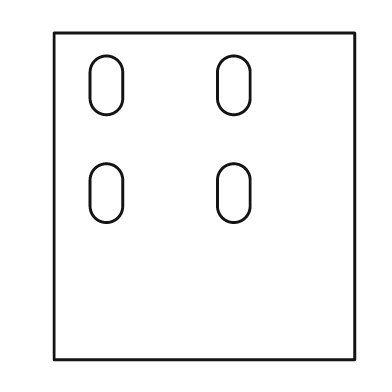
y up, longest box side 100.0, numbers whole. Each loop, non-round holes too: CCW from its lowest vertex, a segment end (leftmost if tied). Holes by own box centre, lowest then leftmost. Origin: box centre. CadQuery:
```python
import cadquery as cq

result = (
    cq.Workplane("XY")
    .moveTo(-46.0, -50.0)
    .lineTo(46.0, -50.0)
    .lineTo(46.0, 50.0)
    .lineTo(-46.0, 50.0)
    .close()
    .moveTo(-35.0, -3.0)
    .threePointArc((-30.0, -8.0), (-25.0, -3.0))
    .lineTo(-25.0, 5.0)
    .threePointArc((-30.0, 10.0), (-35.0, 5.0))
    .close()
    .moveTo(4.0, -3.0)
    .threePointArc((9.0, -8.0), (14.0, -3.0))
    .lineTo(14.0, 5.0)
    .threePointArc((9.0, 10.0), (4.0, 5.0))
    .close()
    .moveTo(-35.0, 30.0)
    .threePointArc((-30.0, 25.0), (-25.0, 30.0))
    .lineTo(-25.0, 38.0)
    .threePointArc((-30.0, 43.0), (-35.0, 38.0))
    .close()
    .moveTo(4.0, 30.0)
    .threePointArc((9.0, 25.0), (14.0, 30.0))
    .lineTo(14.0, 38.0)
    .threePointArc((9.0, 43.0), (4.0, 38.0))
    .close()
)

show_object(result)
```